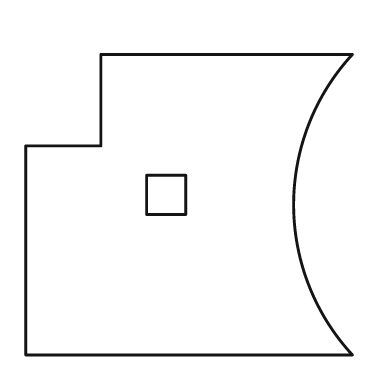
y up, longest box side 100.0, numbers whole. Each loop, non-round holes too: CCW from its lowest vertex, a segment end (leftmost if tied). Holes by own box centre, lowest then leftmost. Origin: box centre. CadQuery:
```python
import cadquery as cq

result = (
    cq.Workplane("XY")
    .moveTo(-50.0, -46.0)
    .lineTo(50.0, -46.0)
    .threePointArc((32.0, 0.0), (50.0, 46.0))
    .lineTo(-27.0, 46.0)
    .lineTo(-27.0, 18.0)
    .lineTo(-50.0, 18.0)
    .close()
    .moveTo(-13.0, -3.0)
    .lineTo(-1.0, -3.0)
    .lineTo(-1.0, 9.0)
    .lineTo(-13.0, 9.0)
    .close()
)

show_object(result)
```